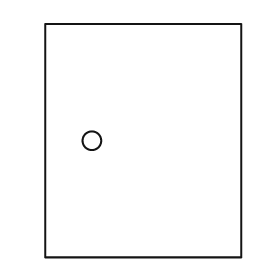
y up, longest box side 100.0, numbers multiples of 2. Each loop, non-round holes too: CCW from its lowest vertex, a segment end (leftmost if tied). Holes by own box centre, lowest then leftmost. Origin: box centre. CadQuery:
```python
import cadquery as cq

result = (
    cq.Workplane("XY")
    .moveTo(-42.0, -50.0)
    .lineTo(42.0, -50.0)
    .lineTo(42.0, 50.0)
    .lineTo(-42.0, 50.0)
    .close()
    .moveTo(-22.0, 0.0)
    .circle(4.0)
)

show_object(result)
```